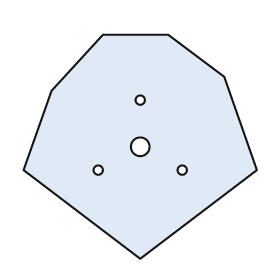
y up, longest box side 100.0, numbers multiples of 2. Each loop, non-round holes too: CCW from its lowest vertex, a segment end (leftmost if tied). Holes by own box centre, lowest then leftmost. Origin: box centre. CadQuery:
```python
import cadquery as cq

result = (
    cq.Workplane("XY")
    .moveTo(0.0, -48.0)
    .lineTo(50.0, -10.0)
    .lineTo(36.0, 30.0)
    .lineTo(12.0, 48.0)
    .lineTo(-16.0, 48.0)
    .lineTo(-38.0, 24.0)
    .lineTo(-50.0, -10.0)
    .close()
    .moveTo(-18.0, -10.0)
    .circle(2.0)
    .moveTo(18.0, -10.0)
    .circle(2.0)
    .moveTo(0.0, 0.0)
    .circle(4.0)
    .moveTo(0.0, 20.0)
    .circle(2.0)
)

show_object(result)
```